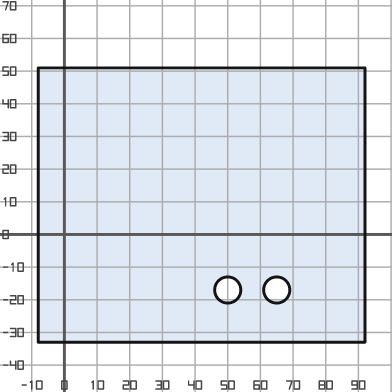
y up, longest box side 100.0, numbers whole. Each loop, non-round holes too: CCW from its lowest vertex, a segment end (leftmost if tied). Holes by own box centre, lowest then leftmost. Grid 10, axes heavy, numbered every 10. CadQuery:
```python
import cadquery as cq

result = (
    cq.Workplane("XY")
    .moveTo(-8.0, -33.0)
    .lineTo(92.0, -33.0)
    .lineTo(92.0, 51.0)
    .lineTo(-8.0, 51.0)
    .close()
    .moveTo(50.0, -17.0)
    .circle(4.0)
    .moveTo(65.0, -17.0)
    .circle(4.0)
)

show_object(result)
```